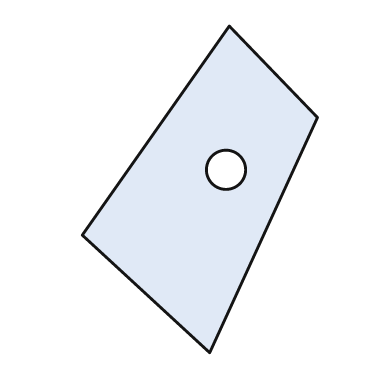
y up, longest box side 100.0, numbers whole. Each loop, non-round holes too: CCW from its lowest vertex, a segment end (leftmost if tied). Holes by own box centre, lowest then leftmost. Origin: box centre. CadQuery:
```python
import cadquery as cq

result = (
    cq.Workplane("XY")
    .moveTo(3.0, -50.0)
    .lineTo(36.0, 22.0)
    .lineTo(9.0, 50.0)
    .lineTo(-36.0, -14.0)
    .close()
    .moveTo(8.0, 6.0)
    .circle(6.0)
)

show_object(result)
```